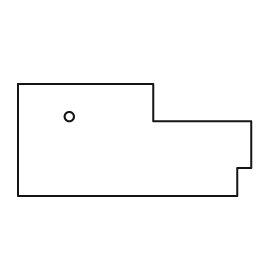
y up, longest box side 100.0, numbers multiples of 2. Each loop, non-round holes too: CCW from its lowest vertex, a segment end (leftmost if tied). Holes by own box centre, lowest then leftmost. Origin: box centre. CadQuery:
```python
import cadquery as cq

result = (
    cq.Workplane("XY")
    .moveTo(-50.0, -24.0)
    .lineTo(44.0, -24.0)
    .lineTo(44.0, -12.0)
    .lineTo(50.0, -12.0)
    .lineTo(50.0, 8.0)
    .lineTo(8.0, 8.0)
    .lineTo(8.0, 24.0)
    .lineTo(-50.0, 24.0)
    .close()
    .moveTo(-28.0, 10.0)
    .circle(2.0)
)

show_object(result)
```